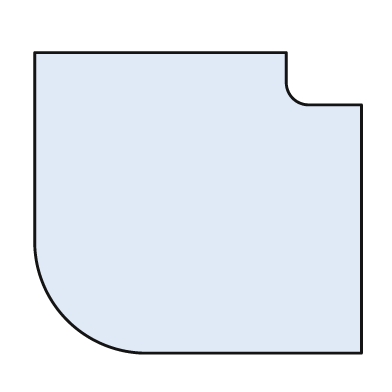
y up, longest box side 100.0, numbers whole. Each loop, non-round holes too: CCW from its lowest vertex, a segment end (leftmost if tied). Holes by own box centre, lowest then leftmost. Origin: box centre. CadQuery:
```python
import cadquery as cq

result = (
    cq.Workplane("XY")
    .moveTo(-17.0, -46.0)
    .lineTo(50.0, -46.0)
    .lineTo(50.0, 30.0)
    .lineTo(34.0, 30.0)
    .threePointArc((29.0, 32.0), (27.0, 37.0))
    .lineTo(27.0, 46.0)
    .lineTo(-50.0, 46.0)
    .lineTo(-50.0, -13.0)
    .threePointArc((-40.0, -36.0), (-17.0, -46.0))
    .close()
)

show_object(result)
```